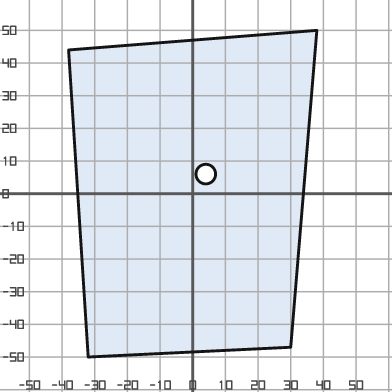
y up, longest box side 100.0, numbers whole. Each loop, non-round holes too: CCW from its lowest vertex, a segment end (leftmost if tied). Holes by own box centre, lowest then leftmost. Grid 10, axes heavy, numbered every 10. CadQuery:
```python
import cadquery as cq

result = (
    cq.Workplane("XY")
    .moveTo(-32.0, -50.0)
    .lineTo(30.0, -47.0)
    .lineTo(38.0, 50.0)
    .lineTo(-38.0, 44.0)
    .close()
    .moveTo(4.0, 6.0)
    .circle(3.0)
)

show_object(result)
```